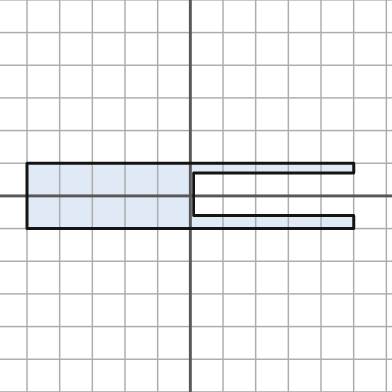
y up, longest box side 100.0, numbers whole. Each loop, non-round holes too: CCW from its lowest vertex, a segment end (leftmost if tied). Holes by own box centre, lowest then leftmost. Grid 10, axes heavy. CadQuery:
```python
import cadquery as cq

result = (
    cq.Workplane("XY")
    .moveTo(-50.0, -10.0)
    .lineTo(50.0, -10.0)
    .lineTo(50.0, -6.0)
    .lineTo(1.0, -6.0)
    .lineTo(1.0, 7.0)
    .lineTo(50.0, 7.0)
    .lineTo(50.0, 10.0)
    .lineTo(-50.0, 10.0)
    .close()
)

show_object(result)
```